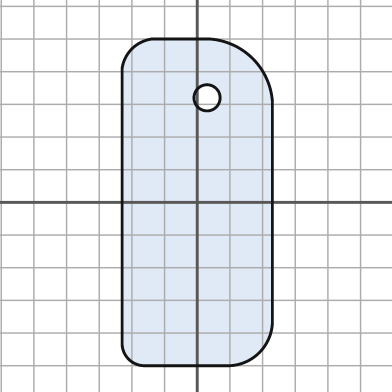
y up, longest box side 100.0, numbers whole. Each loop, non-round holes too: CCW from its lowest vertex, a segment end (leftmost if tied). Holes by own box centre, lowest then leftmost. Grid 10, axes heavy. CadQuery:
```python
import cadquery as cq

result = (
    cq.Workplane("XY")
    .moveTo(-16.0, -50.0)
    .lineTo(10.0, -50.0)
    .threePointArc((19.0, -46.0), (23.0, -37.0))
    .lineTo(23.0, 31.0)
    .threePointArc((17.0, 44.0), (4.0, 50.0))
    .lineTo(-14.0, 50.0)
    .threePointArc((-20.0, 47.0), (-23.0, 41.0))
    .lineTo(-23.0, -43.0)
    .threePointArc((-21.0, -48.0), (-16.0, -50.0))
    .close()
    .moveTo(3.0, 32.0)
    .circle(4.0)
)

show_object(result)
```